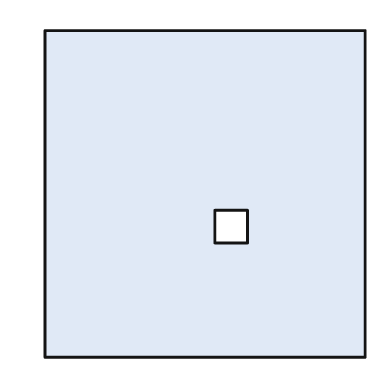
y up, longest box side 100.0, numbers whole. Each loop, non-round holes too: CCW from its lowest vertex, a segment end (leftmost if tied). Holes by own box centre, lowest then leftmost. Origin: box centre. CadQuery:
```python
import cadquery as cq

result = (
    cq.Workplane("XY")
    .moveTo(-49.0, -50.0)
    .lineTo(49.0, -50.0)
    .lineTo(49.0, 50.0)
    .lineTo(-49.0, 50.0)
    .close()
    .moveTo(3.0, -15.0)
    .lineTo(13.0, -15.0)
    .lineTo(13.0, -5.0)
    .lineTo(3.0, -5.0)
    .close()
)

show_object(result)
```